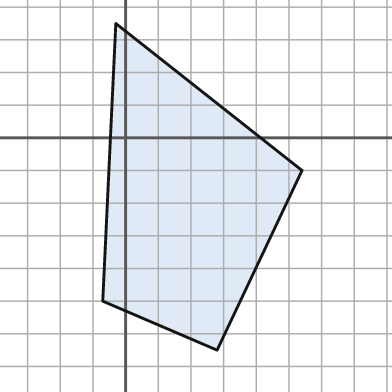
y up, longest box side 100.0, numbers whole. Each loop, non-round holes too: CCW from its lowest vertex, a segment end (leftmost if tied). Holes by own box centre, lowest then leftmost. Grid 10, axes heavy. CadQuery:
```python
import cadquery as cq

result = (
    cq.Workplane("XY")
    .moveTo(28.0, -65.0)
    .lineTo(54.0, -10.0)
    .lineTo(-3.0, 35.0)
    .lineTo(-7.0, -50.0)
    .close()
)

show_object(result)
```